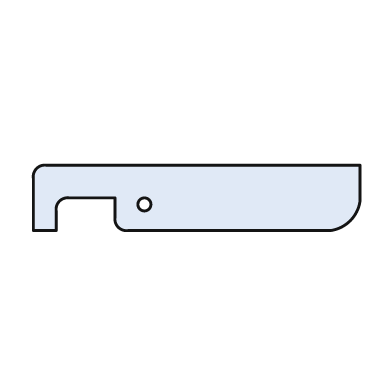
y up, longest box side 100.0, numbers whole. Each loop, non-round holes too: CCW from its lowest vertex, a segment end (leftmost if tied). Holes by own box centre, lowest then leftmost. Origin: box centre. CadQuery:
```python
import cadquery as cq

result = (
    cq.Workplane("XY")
    .moveTo(-50.0, -10.0)
    .lineTo(-43.0, -10.0)
    .lineTo(-43.0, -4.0)
    .threePointArc((-42.0, -1.0), (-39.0, 0.0))
    .lineTo(-25.0, 0.0)
    .lineTo(-25.0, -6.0)
    .threePointArc((-24.0, -9.0), (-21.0, -10.0))
    .lineTo(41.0, -10.0)
    .threePointArc((47.0, -7.0), (50.0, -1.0))
    .lineTo(50.0, 10.0)
    .lineTo(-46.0, 10.0)
    .threePointArc((-49.0, 9.0), (-50.0, 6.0))
    .close()
    .moveTo(-16.0, -2.0)
    .circle(2.0)
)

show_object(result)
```